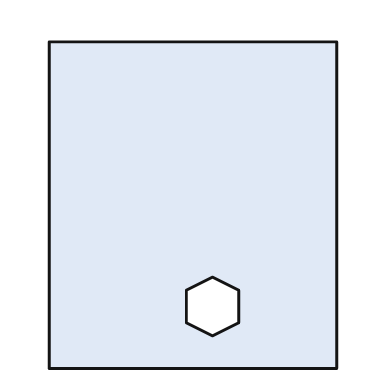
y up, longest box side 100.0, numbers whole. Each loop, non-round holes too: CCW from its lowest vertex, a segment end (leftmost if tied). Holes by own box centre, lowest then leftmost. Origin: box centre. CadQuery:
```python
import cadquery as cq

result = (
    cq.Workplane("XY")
    .moveTo(-44.0, -50.0)
    .lineTo(44.0, -50.0)
    .lineTo(44.0, 50.0)
    .lineTo(-44.0, 50.0)
    .close()
    .moveTo(6.0, -40.0)
    .lineTo(14.0, -36.0)
    .lineTo(14.0, -26.0)
    .lineTo(6.0, -22.0)
    .lineTo(-2.0, -26.0)
    .lineTo(-2.0, -36.0)
    .close()
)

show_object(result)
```